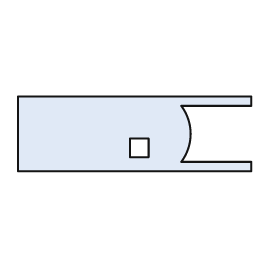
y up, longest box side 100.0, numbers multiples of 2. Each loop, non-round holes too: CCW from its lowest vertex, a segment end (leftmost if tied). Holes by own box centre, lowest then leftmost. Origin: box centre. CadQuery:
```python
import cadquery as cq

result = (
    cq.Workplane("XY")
    .moveTo(-50.0, -16.0)
    .lineTo(50.0, -16.0)
    .lineTo(50.0, -12.0)
    .lineTo(20.0, -12.0)
    .threePointArc((24.0, 0.0), (20.0, 12.0))
    .lineTo(50.0, 12.0)
    .lineTo(50.0, 16.0)
    .lineTo(-50.0, 16.0)
    .close()
    .moveTo(-2.0, -10.0)
    .lineTo(6.0, -10.0)
    .lineTo(6.0, -2.0)
    .lineTo(-2.0, -2.0)
    .close()
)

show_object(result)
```